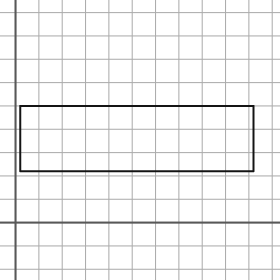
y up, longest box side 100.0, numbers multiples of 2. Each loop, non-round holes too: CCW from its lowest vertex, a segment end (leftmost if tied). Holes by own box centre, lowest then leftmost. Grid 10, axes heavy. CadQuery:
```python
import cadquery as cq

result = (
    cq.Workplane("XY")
    .moveTo(2.0, 22.0)
    .lineTo(102.0, 22.0)
    .lineTo(102.0, 50.0)
    .lineTo(2.0, 50.0)
    .close()
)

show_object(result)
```